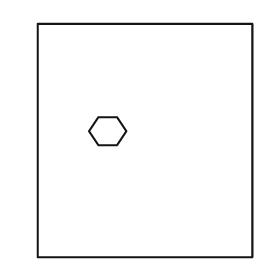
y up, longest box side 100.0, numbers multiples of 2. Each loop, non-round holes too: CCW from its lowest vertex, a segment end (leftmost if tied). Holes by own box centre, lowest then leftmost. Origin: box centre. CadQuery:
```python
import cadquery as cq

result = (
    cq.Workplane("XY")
    .moveTo(-46.0, -50.0)
    .lineTo(46.0, -50.0)
    .lineTo(46.0, 50.0)
    .lineTo(-46.0, 50.0)
    .close()
    .moveTo(-20.0, -2.0)
    .lineTo(-12.0, -2.0)
    .lineTo(-8.0, 4.0)
    .lineTo(-12.0, 10.0)
    .lineTo(-20.0, 10.0)
    .lineTo(-24.0, 4.0)
    .close()
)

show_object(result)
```